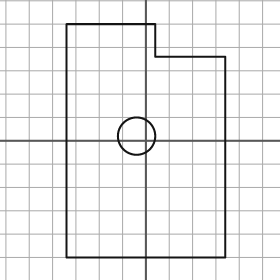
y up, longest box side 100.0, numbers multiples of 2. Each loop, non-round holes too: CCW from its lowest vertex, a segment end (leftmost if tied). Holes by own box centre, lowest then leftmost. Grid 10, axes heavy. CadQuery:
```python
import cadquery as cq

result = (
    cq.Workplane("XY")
    .moveTo(-34.0, -50.0)
    .lineTo(34.0, -50.0)
    .lineTo(34.0, 36.0)
    .lineTo(4.0, 36.0)
    .lineTo(4.0, 50.0)
    .lineTo(-34.0, 50.0)
    .close()
    .moveTo(-4.0, 2.0)
    .circle(8.0)
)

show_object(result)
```